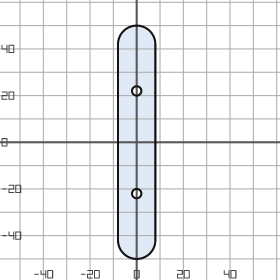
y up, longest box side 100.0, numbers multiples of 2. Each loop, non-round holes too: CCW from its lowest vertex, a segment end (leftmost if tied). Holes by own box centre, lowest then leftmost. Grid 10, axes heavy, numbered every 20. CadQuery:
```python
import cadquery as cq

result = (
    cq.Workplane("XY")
    .moveTo(-8.0, -42.0)
    .threePointArc((0.0, -50.0), (8.0, -42.0))
    .lineTo(8.0, 42.0)
    .threePointArc((0.0, 50.0), (-8.0, 42.0))
    .close()
    .moveTo(0.0, -22.0)
    .circle(2.0)
    .moveTo(0.0, 22.0)
    .circle(2.0)
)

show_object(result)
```